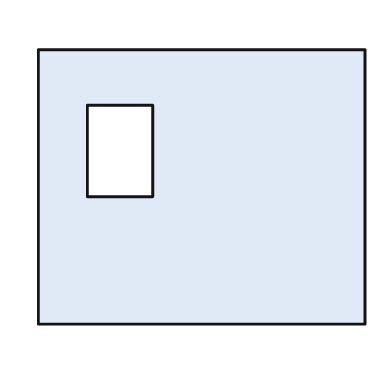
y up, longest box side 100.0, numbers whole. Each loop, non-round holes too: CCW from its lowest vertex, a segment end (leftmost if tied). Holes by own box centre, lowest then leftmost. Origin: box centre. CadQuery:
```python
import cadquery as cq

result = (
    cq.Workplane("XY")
    .moveTo(-50.0, -42.0)
    .lineTo(50.0, -42.0)
    .lineTo(50.0, 42.0)
    .lineTo(-50.0, 42.0)
    .close()
    .moveTo(-35.0, -3.0)
    .lineTo(-15.0, -3.0)
    .lineTo(-15.0, 25.0)
    .lineTo(-35.0, 25.0)
    .close()
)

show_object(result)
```